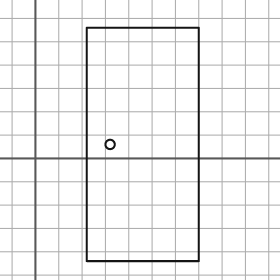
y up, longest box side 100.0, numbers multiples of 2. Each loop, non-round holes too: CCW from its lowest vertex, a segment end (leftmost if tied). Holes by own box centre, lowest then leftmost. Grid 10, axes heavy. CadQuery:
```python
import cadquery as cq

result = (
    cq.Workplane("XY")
    .moveTo(22.0, -44.0)
    .lineTo(70.0, -44.0)
    .lineTo(70.0, 56.0)
    .lineTo(22.0, 56.0)
    .close()
    .moveTo(32.0, 6.0)
    .circle(2.0)
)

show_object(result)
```